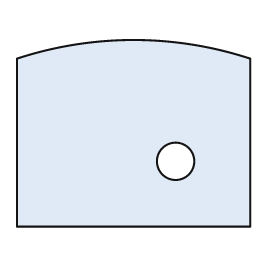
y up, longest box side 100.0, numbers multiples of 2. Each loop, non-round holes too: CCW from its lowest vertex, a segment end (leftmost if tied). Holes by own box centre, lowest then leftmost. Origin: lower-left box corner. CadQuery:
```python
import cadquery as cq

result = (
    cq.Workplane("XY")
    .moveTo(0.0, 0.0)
    .lineTo(100.0, 0.0)
    .lineTo(100.0, 72.0)
    .threePointArc((50.0, 80.0), (0.0, 72.0))
    .close()
    .moveTo(68.0, 28.0)
    .circle(8.0)
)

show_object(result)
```